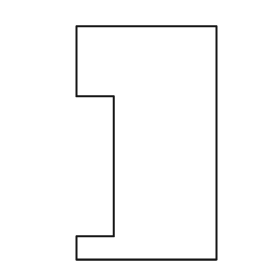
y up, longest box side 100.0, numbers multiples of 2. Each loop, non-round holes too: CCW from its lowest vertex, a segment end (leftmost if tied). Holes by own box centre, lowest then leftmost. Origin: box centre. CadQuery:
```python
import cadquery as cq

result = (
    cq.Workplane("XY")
    .moveTo(-30.0, -50.0)
    .lineTo(30.0, -50.0)
    .lineTo(30.0, 50.0)
    .lineTo(-30.0, 50.0)
    .lineTo(-30.0, 20.0)
    .lineTo(-14.0, 20.0)
    .lineTo(-14.0, -40.0)
    .lineTo(-30.0, -40.0)
    .close()
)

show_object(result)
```